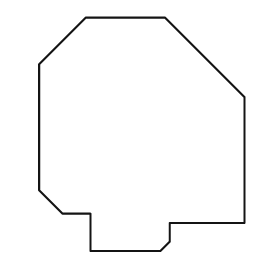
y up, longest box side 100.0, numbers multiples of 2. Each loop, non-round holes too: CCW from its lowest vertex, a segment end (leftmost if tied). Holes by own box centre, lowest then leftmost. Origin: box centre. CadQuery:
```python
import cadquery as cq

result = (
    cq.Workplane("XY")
    .moveTo(-22.0, -50.0)
    .lineTo(8.0, -50.0)
    .lineTo(12.0, -46.0)
    .lineTo(12.0, -38.0)
    .lineTo(44.0, -38.0)
    .lineTo(44.0, 16.0)
    .lineTo(10.0, 50.0)
    .lineTo(-24.0, 50.0)
    .lineTo(-44.0, 30.0)
    .lineTo(-44.0, -24.0)
    .lineTo(-34.0, -34.0)
    .lineTo(-22.0, -34.0)
    .close()
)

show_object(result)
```